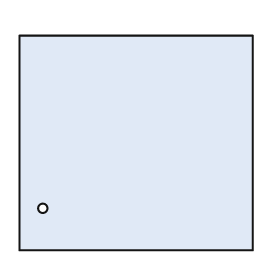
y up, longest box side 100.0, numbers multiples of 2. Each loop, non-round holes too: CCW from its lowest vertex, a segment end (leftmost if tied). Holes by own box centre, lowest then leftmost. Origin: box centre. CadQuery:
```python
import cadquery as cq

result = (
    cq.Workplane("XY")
    .moveTo(-50.0, -46.0)
    .lineTo(50.0, -46.0)
    .lineTo(50.0, 46.0)
    .lineTo(-50.0, 46.0)
    .close()
    .moveTo(-40.0, -28.0)
    .circle(2.0)
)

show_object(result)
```